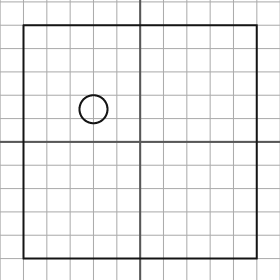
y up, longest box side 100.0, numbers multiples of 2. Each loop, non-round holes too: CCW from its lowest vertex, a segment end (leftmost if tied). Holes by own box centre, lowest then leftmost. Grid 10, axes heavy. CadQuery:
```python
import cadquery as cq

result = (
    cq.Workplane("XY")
    .moveTo(-50.0, -50.0)
    .lineTo(50.0, -50.0)
    .lineTo(50.0, 50.0)
    .lineTo(-50.0, 50.0)
    .close()
    .moveTo(-20.0, 14.0)
    .circle(6.0)
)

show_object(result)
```